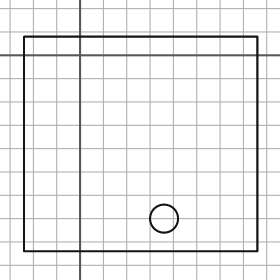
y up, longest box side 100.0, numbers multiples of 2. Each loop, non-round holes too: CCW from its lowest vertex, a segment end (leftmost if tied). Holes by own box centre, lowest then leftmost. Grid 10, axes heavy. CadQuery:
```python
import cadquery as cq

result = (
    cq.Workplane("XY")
    .moveTo(-24.0, -84.0)
    .lineTo(76.0, -84.0)
    .lineTo(76.0, 8.0)
    .lineTo(-24.0, 8.0)
    .close()
    .moveTo(36.0, -70.0)
    .circle(6.0)
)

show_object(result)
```